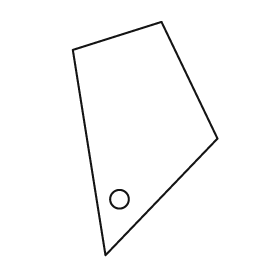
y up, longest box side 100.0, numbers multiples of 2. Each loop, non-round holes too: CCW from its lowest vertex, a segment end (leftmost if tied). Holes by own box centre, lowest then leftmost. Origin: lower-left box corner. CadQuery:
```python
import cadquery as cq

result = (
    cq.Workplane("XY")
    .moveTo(14.0, 0.0)
    .lineTo(62.0, 50.0)
    .lineTo(38.0, 100.0)
    .lineTo(0.0, 88.0)
    .close()
    .moveTo(20.0, 24.0)
    .circle(4.0)
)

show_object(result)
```